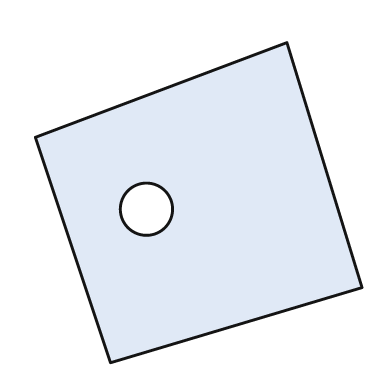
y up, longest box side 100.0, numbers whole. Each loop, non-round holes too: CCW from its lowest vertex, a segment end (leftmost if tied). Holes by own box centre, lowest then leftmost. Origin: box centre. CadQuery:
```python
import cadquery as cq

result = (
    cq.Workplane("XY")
    .moveTo(-27.0, -49.0)
    .lineTo(50.0, -26.0)
    .lineTo(27.0, 49.0)
    .lineTo(-50.0, 20.0)
    .close()
    .moveTo(-16.0, -2.0)
    .circle(8.0)
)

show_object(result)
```